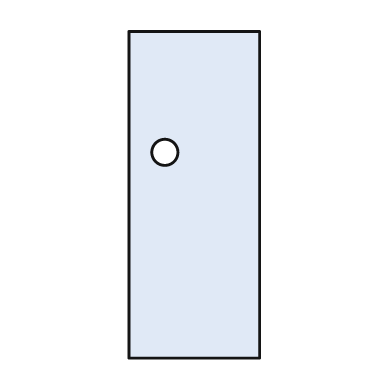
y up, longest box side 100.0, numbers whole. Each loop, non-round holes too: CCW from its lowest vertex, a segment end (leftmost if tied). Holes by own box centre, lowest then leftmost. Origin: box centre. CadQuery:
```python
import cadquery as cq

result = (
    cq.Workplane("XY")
    .moveTo(-20.0, -50.0)
    .lineTo(20.0, -50.0)
    .lineTo(20.0, 50.0)
    .lineTo(-20.0, 50.0)
    .close()
    .moveTo(-9.0, 13.0)
    .circle(4.0)
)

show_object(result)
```